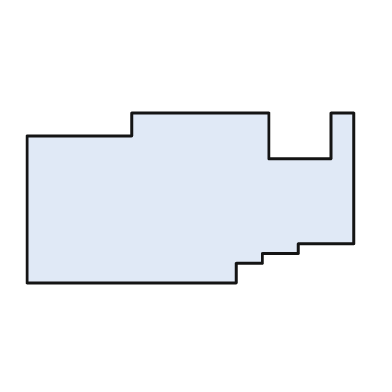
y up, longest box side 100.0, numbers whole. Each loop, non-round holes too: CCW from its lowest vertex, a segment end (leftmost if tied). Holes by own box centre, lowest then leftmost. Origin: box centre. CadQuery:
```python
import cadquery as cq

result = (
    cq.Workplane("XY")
    .moveTo(-50.0, -26.0)
    .lineTo(14.0, -26.0)
    .lineTo(14.0, -20.0)
    .lineTo(22.0, -20.0)
    .lineTo(22.0, -17.0)
    .lineTo(33.0, -17.0)
    .lineTo(33.0, -14.0)
    .lineTo(50.0, -14.0)
    .lineTo(50.0, 26.0)
    .lineTo(43.0, 26.0)
    .lineTo(43.0, 12.0)
    .lineTo(24.0, 12.0)
    .lineTo(24.0, 26.0)
    .lineTo(-18.0, 26.0)
    .lineTo(-18.0, 19.0)
    .lineTo(-50.0, 19.0)
    .close()
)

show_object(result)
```